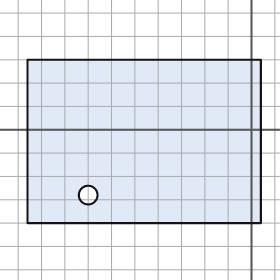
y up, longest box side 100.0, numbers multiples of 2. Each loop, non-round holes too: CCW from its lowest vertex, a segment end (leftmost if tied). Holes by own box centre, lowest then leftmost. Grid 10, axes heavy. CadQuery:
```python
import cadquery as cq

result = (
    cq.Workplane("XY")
    .moveTo(-96.0, -40.0)
    .lineTo(4.0, -40.0)
    .lineTo(4.0, 30.0)
    .lineTo(-96.0, 30.0)
    .close()
    .moveTo(-70.0, -28.0)
    .circle(4.0)
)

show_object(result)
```